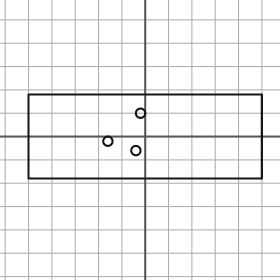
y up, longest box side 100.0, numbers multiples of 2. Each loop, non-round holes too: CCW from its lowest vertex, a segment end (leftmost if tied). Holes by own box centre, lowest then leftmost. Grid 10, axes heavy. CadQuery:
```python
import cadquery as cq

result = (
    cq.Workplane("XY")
    .moveTo(-50.0, -18.0)
    .lineTo(50.0, -18.0)
    .lineTo(50.0, 18.0)
    .lineTo(-50.0, 18.0)
    .close()
    .moveTo(-4.0, -6.0)
    .circle(2.0)
    .moveTo(-16.0, -2.0)
    .circle(2.0)
    .moveTo(-2.0, 10.0)
    .circle(2.0)
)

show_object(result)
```